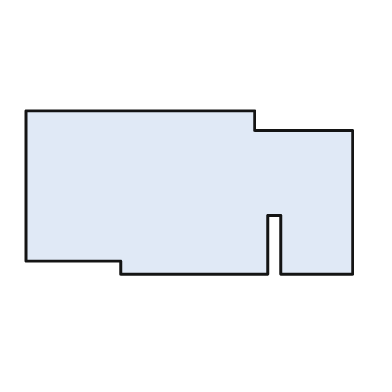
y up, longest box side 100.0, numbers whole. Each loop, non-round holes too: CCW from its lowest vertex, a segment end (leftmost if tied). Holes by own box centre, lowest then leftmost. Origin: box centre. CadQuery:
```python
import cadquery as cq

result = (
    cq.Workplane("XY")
    .moveTo(-21.0, -25.0)
    .lineTo(24.0, -25.0)
    .lineTo(24.0, -7.0)
    .lineTo(28.0, -7.0)
    .lineTo(28.0, -25.0)
    .lineTo(50.0, -25.0)
    .lineTo(50.0, 19.0)
    .lineTo(20.0, 19.0)
    .lineTo(20.0, 25.0)
    .lineTo(-50.0, 25.0)
    .lineTo(-50.0, -21.0)
    .lineTo(-21.0, -21.0)
    .close()
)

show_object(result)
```